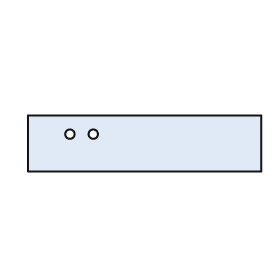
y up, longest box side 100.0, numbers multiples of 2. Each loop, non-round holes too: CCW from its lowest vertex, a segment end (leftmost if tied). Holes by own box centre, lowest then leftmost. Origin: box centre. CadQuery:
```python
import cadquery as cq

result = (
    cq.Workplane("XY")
    .moveTo(-50.0, -12.0)
    .lineTo(50.0, -12.0)
    .lineTo(50.0, 12.0)
    .lineTo(-50.0, 12.0)
    .close()
    .moveTo(-32.0, 4.0)
    .circle(2.0)
    .moveTo(-22.0, 4.0)
    .circle(2.0)
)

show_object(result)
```